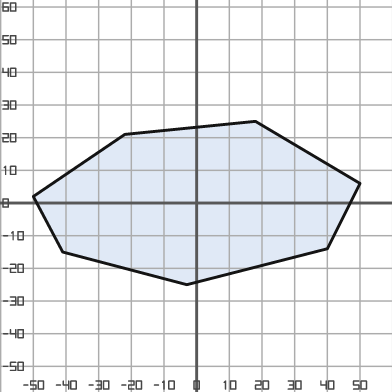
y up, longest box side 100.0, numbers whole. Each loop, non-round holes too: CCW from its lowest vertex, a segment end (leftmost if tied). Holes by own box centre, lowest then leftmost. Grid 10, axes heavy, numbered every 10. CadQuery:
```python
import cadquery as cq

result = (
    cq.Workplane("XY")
    .moveTo(-3.0, -25.0)
    .lineTo(40.0, -14.0)
    .lineTo(50.0, 6.0)
    .lineTo(18.0, 25.0)
    .lineTo(-22.0, 21.0)
    .lineTo(-50.0, 2.0)
    .lineTo(-41.0, -15.0)
    .close()
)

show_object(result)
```